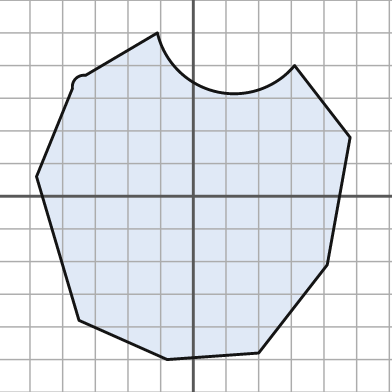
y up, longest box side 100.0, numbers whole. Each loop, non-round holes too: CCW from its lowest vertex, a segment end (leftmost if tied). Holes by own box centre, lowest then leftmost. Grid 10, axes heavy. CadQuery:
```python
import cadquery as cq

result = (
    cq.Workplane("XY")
    .moveTo(-8.0, -50.0)
    .lineTo(20.0, -48.0)
    .lineTo(41.0, -21.0)
    .lineTo(48.0, 18.0)
    .lineTo(31.0, 40.0)
    .threePointArc((7.0, 32.0), (-11.0, 50.0))
    .lineTo(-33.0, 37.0)
    .threePointArc((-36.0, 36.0), (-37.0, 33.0))
    .lineTo(-48.0, 6.0)
    .lineTo(-35.0, -38.0)
    .close()
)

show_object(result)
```